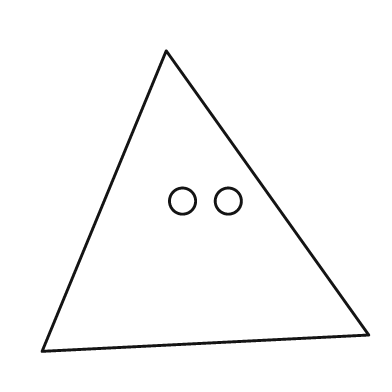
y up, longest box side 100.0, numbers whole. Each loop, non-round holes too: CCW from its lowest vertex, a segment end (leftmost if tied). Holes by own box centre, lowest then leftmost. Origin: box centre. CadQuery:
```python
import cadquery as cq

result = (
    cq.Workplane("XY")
    .moveTo(-50.0, -46.0)
    .lineTo(50.0, -41.0)
    .lineTo(-12.0, 46.0)
    .close()
    .moveTo(-7.0, 0.0)
    .circle(4.0)
    .moveTo(7.0, 0.0)
    .circle(4.0)
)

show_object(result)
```